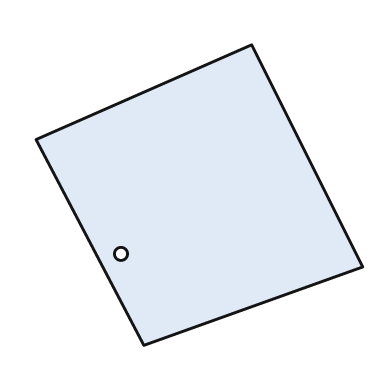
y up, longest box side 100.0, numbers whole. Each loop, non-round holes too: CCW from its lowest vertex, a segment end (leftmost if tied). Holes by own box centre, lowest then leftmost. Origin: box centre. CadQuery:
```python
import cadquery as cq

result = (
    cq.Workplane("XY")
    .moveTo(-17.0, -46.0)
    .lineTo(50.0, -22.0)
    .lineTo(16.0, 46.0)
    .lineTo(-50.0, 17.0)
    .close()
    .moveTo(-24.0, -18.0)
    .circle(2.0)
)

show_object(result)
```